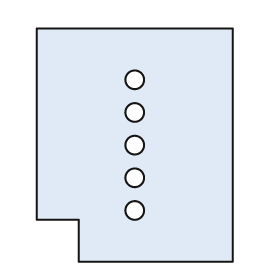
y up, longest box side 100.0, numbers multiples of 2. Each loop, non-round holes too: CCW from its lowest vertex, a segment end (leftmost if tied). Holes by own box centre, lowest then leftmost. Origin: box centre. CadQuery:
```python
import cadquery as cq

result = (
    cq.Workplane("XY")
    .moveTo(-24.0, -50.0)
    .lineTo(42.0, -50.0)
    .lineTo(42.0, 50.0)
    .lineTo(-42.0, 50.0)
    .lineTo(-42.0, -32.0)
    .lineTo(-24.0, -32.0)
    .close()
    .moveTo(0.0, -28.0)
    .circle(4.0)
    .moveTo(0.0, -14.0)
    .circle(4.0)
    .moveTo(0.0, 0.0)
    .circle(4.0)
    .moveTo(0.0, 14.0)
    .circle(4.0)
    .moveTo(0.0, 28.0)
    .circle(4.0)
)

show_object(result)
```